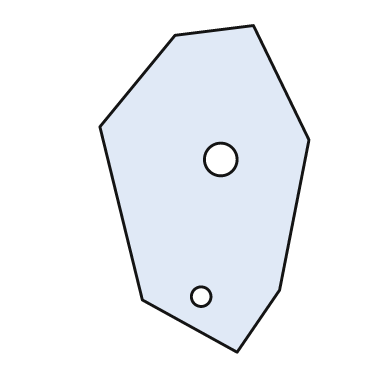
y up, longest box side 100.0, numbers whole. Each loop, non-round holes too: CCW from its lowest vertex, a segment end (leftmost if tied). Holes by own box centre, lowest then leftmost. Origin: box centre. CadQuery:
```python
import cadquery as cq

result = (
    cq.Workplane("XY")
    .moveTo(10.0, -50.0)
    .lineTo(23.0, -31.0)
    .lineTo(32.0, 15.0)
    .lineTo(15.0, 50.0)
    .lineTo(-9.0, 47.0)
    .lineTo(-32.0, 19.0)
    .lineTo(-19.0, -34.0)
    .close()
    .moveTo(-1.0, -33.0)
    .circle(3.0)
    .moveTo(5.0, 9.0)
    .circle(5.0)
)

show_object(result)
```